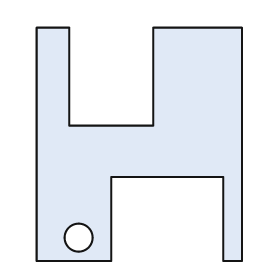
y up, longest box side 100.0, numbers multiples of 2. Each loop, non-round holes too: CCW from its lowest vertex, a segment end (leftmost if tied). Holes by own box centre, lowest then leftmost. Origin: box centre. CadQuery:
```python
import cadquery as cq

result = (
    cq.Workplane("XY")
    .moveTo(-44.0, -50.0)
    .lineTo(-12.0, -50.0)
    .lineTo(-12.0, -14.0)
    .lineTo(36.0, -14.0)
    .lineTo(36.0, -50.0)
    .lineTo(44.0, -50.0)
    .lineTo(44.0, 50.0)
    .lineTo(6.0, 50.0)
    .lineTo(6.0, 8.0)
    .lineTo(-30.0, 8.0)
    .lineTo(-30.0, 50.0)
    .lineTo(-44.0, 50.0)
    .close()
    .moveTo(-26.0, -40.0)
    .circle(6.0)
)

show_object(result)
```